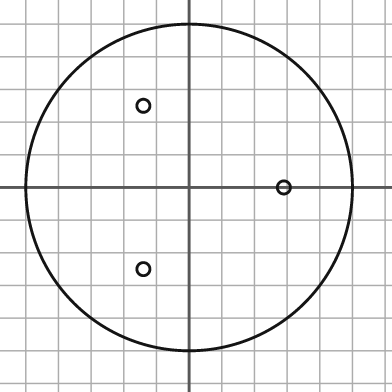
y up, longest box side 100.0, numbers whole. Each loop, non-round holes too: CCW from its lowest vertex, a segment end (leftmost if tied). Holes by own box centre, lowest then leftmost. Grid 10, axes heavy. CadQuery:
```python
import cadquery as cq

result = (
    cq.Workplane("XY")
    .moveTo(0.0, 0.0)
    .circle(50.0)
    .moveTo(-14.0, -25.0)
    .circle(2.0)
    .moveTo(29.0, 0.0)
    .circle(2.0)
    .moveTo(-14.0, 25.0)
    .circle(2.0)
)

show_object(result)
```